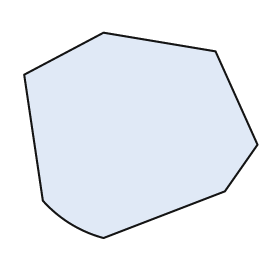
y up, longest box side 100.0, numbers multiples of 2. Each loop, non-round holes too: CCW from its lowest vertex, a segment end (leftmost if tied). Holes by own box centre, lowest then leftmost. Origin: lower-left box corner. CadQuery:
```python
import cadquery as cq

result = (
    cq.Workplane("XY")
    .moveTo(34.0, 0.0)
    .lineTo(86.0, 20.0)
    .lineTo(100.0, 40.0)
    .lineTo(82.0, 80.0)
    .lineTo(34.0, 88.0)
    .lineTo(0.0, 70.0)
    .lineTo(8.0, 16.0)
    .threePointArc((20.0, 6.0), (34.0, 0.0))
    .close()
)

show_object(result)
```